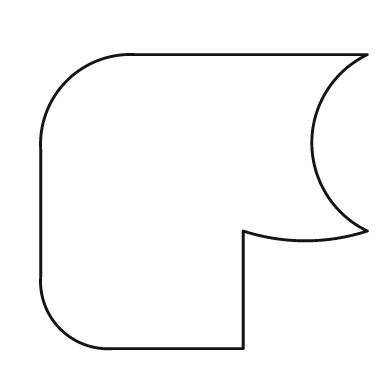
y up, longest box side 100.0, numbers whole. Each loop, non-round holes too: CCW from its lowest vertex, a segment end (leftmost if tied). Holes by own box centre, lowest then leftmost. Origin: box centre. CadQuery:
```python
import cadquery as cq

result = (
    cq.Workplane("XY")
    .moveTo(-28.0, -45.0)
    .lineTo(12.0, -45.0)
    .lineTo(12.0, -9.0)
    .threePointArc((31.0, -12.0), (50.0, -9.0))
    .threePointArc((33.0, 18.0), (50.0, 45.0))
    .lineTo(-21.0, 45.0)
    .threePointArc((-42.0, 37.0), (-50.0, 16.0))
    .lineTo(-50.0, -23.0)
    .threePointArc((-44.0, -39.0), (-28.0, -45.0))
    .close()
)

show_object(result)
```